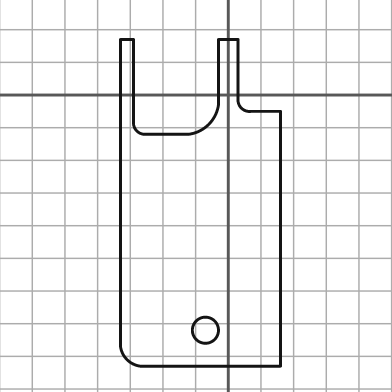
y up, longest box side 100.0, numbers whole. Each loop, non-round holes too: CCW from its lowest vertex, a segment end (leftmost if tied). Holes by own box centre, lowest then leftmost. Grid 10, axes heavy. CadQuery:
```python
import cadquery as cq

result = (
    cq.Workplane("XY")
    .moveTo(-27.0, -83.0)
    .lineTo(16.0, -83.0)
    .lineTo(16.0, -5.0)
    .lineTo(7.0, -5.0)
    .threePointArc((4.0, -4.0), (3.0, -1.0))
    .lineTo(3.0, 17.0)
    .lineTo(-3.0, 17.0)
    .lineTo(-3.0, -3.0)
    .threePointArc((-6.0, -9.0), (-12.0, -12.0))
    .lineTo(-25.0, -12.0)
    .threePointArc((-28.0, -11.0), (-29.0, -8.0))
    .lineTo(-29.0, 17.0)
    .lineTo(-33.0, 17.0)
    .lineTo(-33.0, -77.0)
    .threePointArc((-31.0, -81.0), (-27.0, -83.0))
    .close()
    .moveTo(-7.0, -72.0)
    .circle(4.0)
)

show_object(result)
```